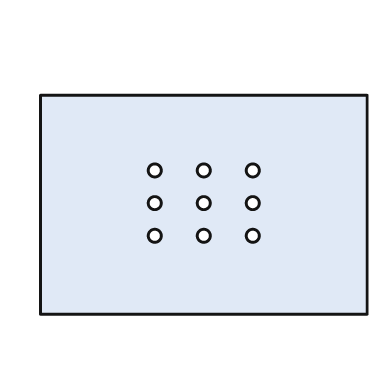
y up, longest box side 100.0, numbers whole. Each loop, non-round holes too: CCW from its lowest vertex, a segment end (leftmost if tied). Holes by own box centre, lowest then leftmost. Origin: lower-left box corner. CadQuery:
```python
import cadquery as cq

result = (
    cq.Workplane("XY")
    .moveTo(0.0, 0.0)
    .lineTo(100.0, 0.0)
    .lineTo(100.0, 67.0)
    .lineTo(0.0, 67.0)
    .close()
    .moveTo(35.0, 24.0)
    .circle(2.0)
    .moveTo(50.0, 24.0)
    .circle(2.0)
    .moveTo(65.0, 24.0)
    .circle(2.0)
    .moveTo(35.0, 34.0)
    .circle(2.0)
    .moveTo(50.0, 34.0)
    .circle(2.0)
    .moveTo(65.0, 34.0)
    .circle(2.0)
    .moveTo(35.0, 44.0)
    .circle(2.0)
    .moveTo(50.0, 44.0)
    .circle(2.0)
    .moveTo(65.0, 44.0)
    .circle(2.0)
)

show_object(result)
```